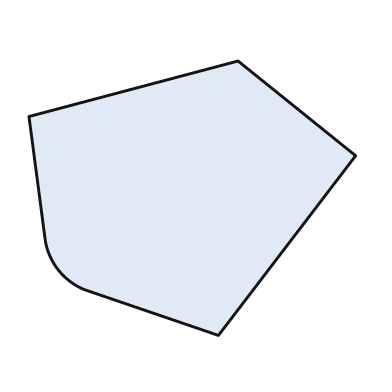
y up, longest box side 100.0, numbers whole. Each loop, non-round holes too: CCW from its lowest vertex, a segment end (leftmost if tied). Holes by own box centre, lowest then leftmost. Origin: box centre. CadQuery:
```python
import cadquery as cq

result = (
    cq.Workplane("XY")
    .moveTo(8.0, -42.0)
    .lineTo(50.0, 13.0)
    .lineTo(14.0, 42.0)
    .lineTo(-50.0, 25.0)
    .lineTo(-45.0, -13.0)
    .threePointArc((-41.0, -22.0), (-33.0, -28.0))
    .close()
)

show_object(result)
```